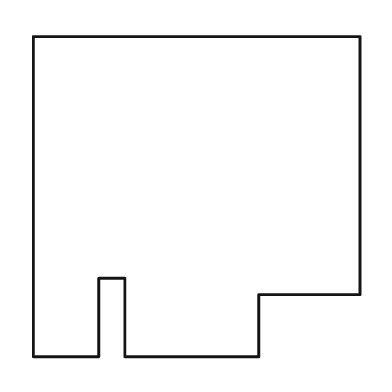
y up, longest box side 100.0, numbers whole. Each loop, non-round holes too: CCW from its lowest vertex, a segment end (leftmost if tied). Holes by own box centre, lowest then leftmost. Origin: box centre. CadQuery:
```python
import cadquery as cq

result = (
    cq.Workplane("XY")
    .moveTo(-50.0, -49.0)
    .lineTo(-30.0, -49.0)
    .lineTo(-30.0, -25.0)
    .lineTo(-22.0, -25.0)
    .lineTo(-22.0, -49.0)
    .lineTo(19.0, -49.0)
    .lineTo(19.0, -30.0)
    .lineTo(50.0, -30.0)
    .lineTo(50.0, 49.0)
    .lineTo(-50.0, 49.0)
    .close()
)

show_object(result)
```